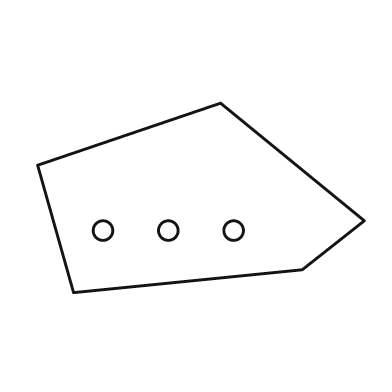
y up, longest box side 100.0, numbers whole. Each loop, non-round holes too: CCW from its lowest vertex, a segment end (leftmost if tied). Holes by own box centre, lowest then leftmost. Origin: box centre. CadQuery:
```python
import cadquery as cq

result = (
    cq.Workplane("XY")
    .moveTo(-39.0, -29.0)
    .lineTo(31.0, -22.0)
    .lineTo(50.0, -7.0)
    .lineTo(6.0, 29.0)
    .lineTo(-50.0, 10.0)
    .close()
    .moveTo(-30.0, -10.0)
    .circle(3.0)
    .moveTo(-10.0, -10.0)
    .circle(3.0)
    .moveTo(10.0, -10.0)
    .circle(3.0)
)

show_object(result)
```